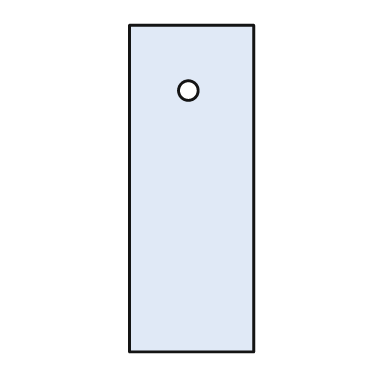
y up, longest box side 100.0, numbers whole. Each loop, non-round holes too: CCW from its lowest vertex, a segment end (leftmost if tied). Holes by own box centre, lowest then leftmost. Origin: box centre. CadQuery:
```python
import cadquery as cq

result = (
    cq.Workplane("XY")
    .moveTo(-19.0, -50.0)
    .lineTo(19.0, -50.0)
    .lineTo(19.0, 50.0)
    .lineTo(-19.0, 50.0)
    .close()
    .moveTo(-1.0, 30.0)
    .circle(3.0)
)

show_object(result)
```